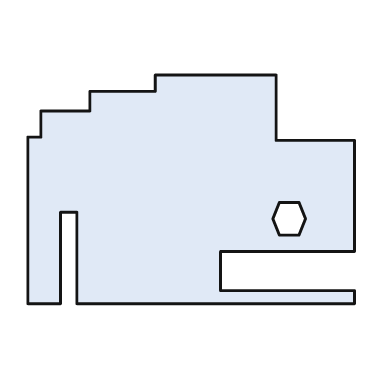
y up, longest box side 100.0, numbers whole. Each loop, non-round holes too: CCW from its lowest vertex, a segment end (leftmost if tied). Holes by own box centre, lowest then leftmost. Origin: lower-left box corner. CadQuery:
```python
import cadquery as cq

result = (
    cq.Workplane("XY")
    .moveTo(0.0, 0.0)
    .lineTo(10.0, 0.0)
    .lineTo(10.0, 28.0)
    .lineTo(15.0, 28.0)
    .lineTo(15.0, 0.0)
    .lineTo(100.0, 0.0)
    .lineTo(100.0, 4.0)
    .lineTo(59.0, 4.0)
    .lineTo(59.0, 16.0)
    .lineTo(100.0, 16.0)
    .lineTo(100.0, 50.0)
    .lineTo(76.0, 50.0)
    .lineTo(76.0, 70.0)
    .lineTo(39.0, 70.0)
    .lineTo(39.0, 65.0)
    .lineTo(19.0, 65.0)
    .lineTo(19.0, 59.0)
    .lineTo(4.0, 59.0)
    .lineTo(4.0, 51.0)
    .lineTo(0.0, 51.0)
    .close()
    .moveTo(77.0, 21.0)
    .lineTo(83.0, 21.0)
    .lineTo(85.0, 26.0)
    .lineTo(83.0, 31.0)
    .lineTo(77.0, 31.0)
    .lineTo(75.0, 26.0)
    .close()
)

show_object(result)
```